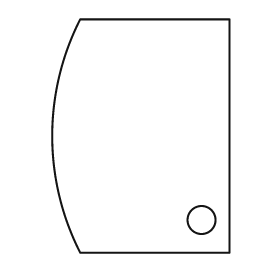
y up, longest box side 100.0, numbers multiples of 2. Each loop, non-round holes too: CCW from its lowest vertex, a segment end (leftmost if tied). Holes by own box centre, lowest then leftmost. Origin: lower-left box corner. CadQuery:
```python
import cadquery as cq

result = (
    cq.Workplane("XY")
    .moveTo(12.0, 0.0)
    .lineTo(76.0, 0.0)
    .lineTo(76.0, 100.0)
    .lineTo(12.0, 100.0)
    .threePointArc((0.0, 50.0), (12.0, 0.0))
    .close()
    .moveTo(64.0, 14.0)
    .circle(6.0)
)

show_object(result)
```